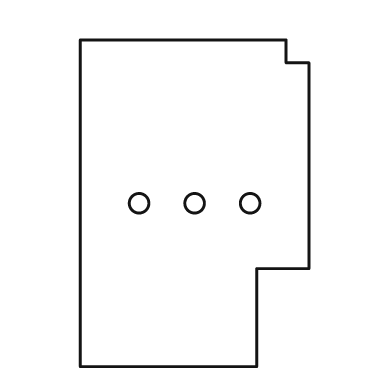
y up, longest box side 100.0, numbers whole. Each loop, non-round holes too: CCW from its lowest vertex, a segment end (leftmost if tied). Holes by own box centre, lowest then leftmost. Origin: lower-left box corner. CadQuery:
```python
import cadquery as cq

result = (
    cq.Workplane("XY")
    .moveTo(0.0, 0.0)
    .lineTo(54.0, 0.0)
    .lineTo(54.0, 30.0)
    .lineTo(70.0, 30.0)
    .lineTo(70.0, 93.0)
    .lineTo(63.0, 93.0)
    .lineTo(63.0, 100.0)
    .lineTo(0.0, 100.0)
    .close()
    .moveTo(18.0, 50.0)
    .circle(3.0)
    .moveTo(35.0, 50.0)
    .circle(3.0)
    .moveTo(52.0, 50.0)
    .circle(3.0)
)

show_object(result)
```